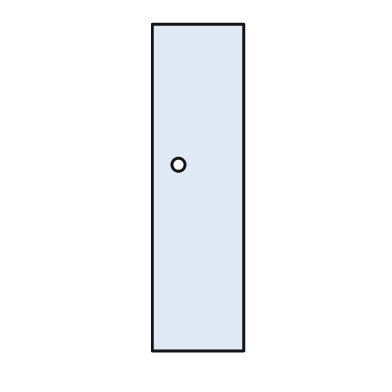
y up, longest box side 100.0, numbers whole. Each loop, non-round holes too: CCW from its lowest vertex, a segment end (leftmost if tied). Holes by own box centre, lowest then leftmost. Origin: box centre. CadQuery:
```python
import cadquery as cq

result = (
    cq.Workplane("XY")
    .moveTo(-14.0, -50.0)
    .lineTo(14.0, -50.0)
    .lineTo(14.0, 50.0)
    .lineTo(-14.0, 50.0)
    .close()
    .moveTo(-6.0, 7.0)
    .circle(2.0)
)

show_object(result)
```